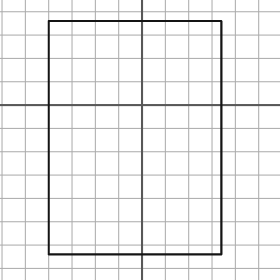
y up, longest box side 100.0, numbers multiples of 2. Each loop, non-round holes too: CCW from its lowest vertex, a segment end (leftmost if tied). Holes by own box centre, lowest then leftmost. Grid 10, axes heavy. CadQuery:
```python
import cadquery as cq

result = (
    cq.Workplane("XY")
    .moveTo(-40.0, -64.0)
    .lineTo(34.0, -64.0)
    .lineTo(34.0, 36.0)
    .lineTo(-40.0, 36.0)
    .close()
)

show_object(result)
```